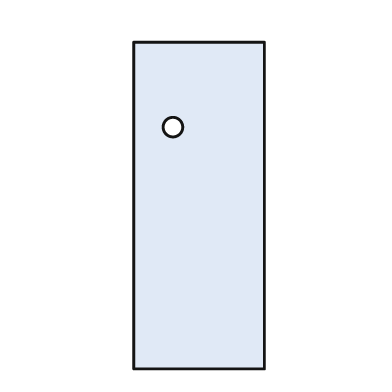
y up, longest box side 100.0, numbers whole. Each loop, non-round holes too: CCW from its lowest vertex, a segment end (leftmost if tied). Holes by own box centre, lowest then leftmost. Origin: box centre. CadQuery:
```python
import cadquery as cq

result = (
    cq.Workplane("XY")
    .moveTo(-20.0, -50.0)
    .lineTo(20.0, -50.0)
    .lineTo(20.0, 50.0)
    .lineTo(-20.0, 50.0)
    .close()
    .moveTo(-8.0, 24.0)
    .circle(3.0)
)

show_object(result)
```